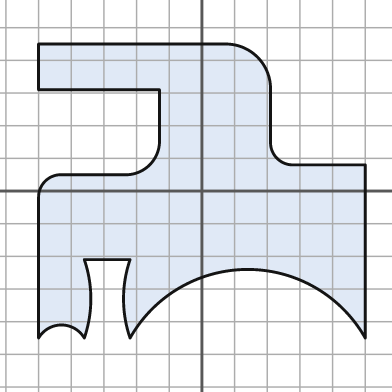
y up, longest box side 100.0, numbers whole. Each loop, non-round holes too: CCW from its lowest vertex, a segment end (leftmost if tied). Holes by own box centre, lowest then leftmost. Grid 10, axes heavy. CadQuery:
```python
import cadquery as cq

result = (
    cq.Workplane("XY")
    .moveTo(-50.0, -45.0)
    .threePointArc((-43.0, -41.0), (-36.0, -45.0))
    .threePointArc((-34.0, -33.0), (-36.0, -21.0))
    .lineTo(-22.0, -21.0)
    .threePointArc((-24.0, -33.0), (-22.0, -45.0))
    .threePointArc((14.0, -24.0), (50.0, -45.0))
    .lineTo(50.0, 8.0)
    .lineTo(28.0, 8.0)
    .threePointArc((23.0, 10.0), (21.0, 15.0))
    .lineTo(21.0, 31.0)
    .threePointArc((17.0, 41.0), (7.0, 45.0))
    .lineTo(-50.0, 45.0)
    .lineTo(-50.0, 31.0)
    .lineTo(-13.0, 31.0)
    .lineTo(-13.0, 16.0)
    .threePointArc((-16.0, 8.0), (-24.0, 5.0))
    .lineTo(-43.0, 5.0)
    .threePointArc((-48.0, 3.0), (-50.0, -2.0))
    .close()
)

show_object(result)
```